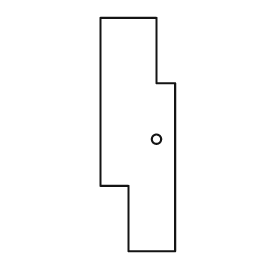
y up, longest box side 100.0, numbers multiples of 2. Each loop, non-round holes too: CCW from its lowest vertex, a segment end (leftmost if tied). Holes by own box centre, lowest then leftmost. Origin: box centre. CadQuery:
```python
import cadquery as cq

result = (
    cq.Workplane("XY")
    .moveTo(-4.0, -50.0)
    .lineTo(16.0, -50.0)
    .lineTo(16.0, 22.0)
    .lineTo(8.0, 22.0)
    .lineTo(8.0, 50.0)
    .lineTo(-16.0, 50.0)
    .lineTo(-16.0, -22.0)
    .lineTo(-4.0, -22.0)
    .close()
    .moveTo(8.0, -2.0)
    .circle(2.0)
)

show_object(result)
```